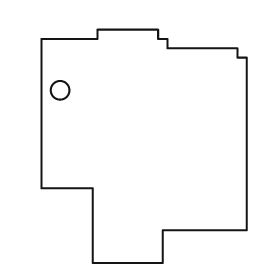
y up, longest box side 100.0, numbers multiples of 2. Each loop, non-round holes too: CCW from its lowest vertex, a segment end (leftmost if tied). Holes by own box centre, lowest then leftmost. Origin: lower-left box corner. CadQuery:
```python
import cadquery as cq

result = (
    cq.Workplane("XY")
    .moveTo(22.0, 0.0)
    .lineTo(52.0, 0.0)
    .lineTo(52.0, 14.0)
    .lineTo(88.0, 14.0)
    .lineTo(88.0, 88.0)
    .lineTo(84.0, 88.0)
    .lineTo(84.0, 92.0)
    .lineTo(54.0, 92.0)
    .lineTo(54.0, 96.0)
    .lineTo(50.0, 96.0)
    .lineTo(50.0, 100.0)
    .lineTo(24.0, 100.0)
    .lineTo(24.0, 96.0)
    .lineTo(0.0, 96.0)
    .lineTo(0.0, 32.0)
    .lineTo(22.0, 32.0)
    .close()
    .moveTo(8.0, 74.0)
    .circle(4.0)
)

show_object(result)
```